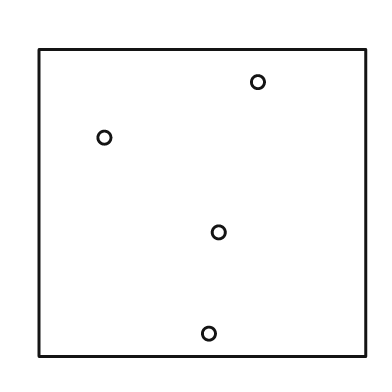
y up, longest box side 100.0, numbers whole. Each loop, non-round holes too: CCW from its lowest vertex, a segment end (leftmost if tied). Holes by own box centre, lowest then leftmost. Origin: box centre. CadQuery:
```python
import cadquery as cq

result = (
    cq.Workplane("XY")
    .moveTo(-50.0, -47.0)
    .lineTo(50.0, -47.0)
    .lineTo(50.0, 47.0)
    .lineTo(-50.0, 47.0)
    .close()
    .moveTo(2.0, -40.0)
    .circle(2.0)
    .moveTo(5.0, -9.0)
    .circle(2.0)
    .moveTo(-30.0, 20.0)
    .circle(2.0)
    .moveTo(17.0, 37.0)
    .circle(2.0)
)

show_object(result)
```